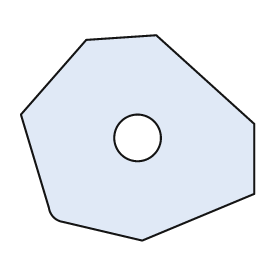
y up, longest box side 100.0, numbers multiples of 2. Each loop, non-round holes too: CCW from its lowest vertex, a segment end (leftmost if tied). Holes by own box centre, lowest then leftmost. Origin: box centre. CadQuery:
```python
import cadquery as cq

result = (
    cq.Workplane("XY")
    .moveTo(2.0, -44.0)
    .lineTo(50.0, -24.0)
    .lineTo(50.0, 6.0)
    .lineTo(8.0, 44.0)
    .lineTo(-22.0, 42.0)
    .lineTo(-50.0, 10.0)
    .lineTo(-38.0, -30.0)
    .threePointArc((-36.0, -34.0), (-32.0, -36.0))
    .close()
    .moveTo(0.0, 0.0)
    .circle(10.0)
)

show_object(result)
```